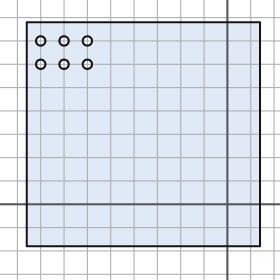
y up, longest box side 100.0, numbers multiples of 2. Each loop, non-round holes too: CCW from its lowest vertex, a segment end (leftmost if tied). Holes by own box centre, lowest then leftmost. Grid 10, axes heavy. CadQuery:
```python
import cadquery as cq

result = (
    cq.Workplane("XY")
    .moveTo(-86.0, -18.0)
    .lineTo(14.0, -18.0)
    .lineTo(14.0, 78.0)
    .lineTo(-86.0, 78.0)
    .close()
    .moveTo(-80.0, 60.0)
    .circle(2.0)
    .moveTo(-70.0, 60.0)
    .circle(2.0)
    .moveTo(-60.0, 60.0)
    .circle(2.0)
    .moveTo(-80.0, 70.0)
    .circle(2.0)
    .moveTo(-70.0, 70.0)
    .circle(2.0)
    .moveTo(-60.0, 70.0)
    .circle(2.0)
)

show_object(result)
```